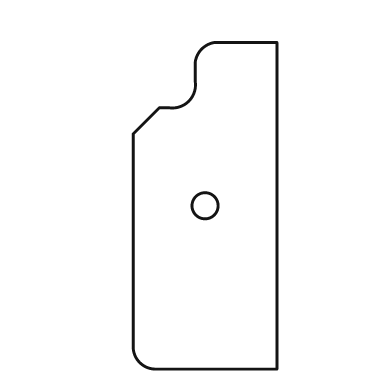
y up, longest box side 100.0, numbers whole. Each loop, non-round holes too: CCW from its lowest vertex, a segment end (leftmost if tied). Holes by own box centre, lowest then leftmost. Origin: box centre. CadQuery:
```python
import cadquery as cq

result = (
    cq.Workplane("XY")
    .moveTo(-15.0, -50.0)
    .lineTo(22.0, -50.0)
    .lineTo(22.0, 50.0)
    .lineTo(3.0, 50.0)
    .threePointArc((-1.0, 48.0), (-3.0, 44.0))
    .lineTo(-3.0, 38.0)
    .threePointArc((-5.0, 32.0), (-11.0, 30.0))
    .lineTo(-14.0, 30.0)
    .lineTo(-22.0, 22.0)
    .lineTo(-22.0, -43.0)
    .threePointArc((-20.0, -48.0), (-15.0, -50.0))
    .close()
    .moveTo(0.0, 0.0)
    .circle(4.0)
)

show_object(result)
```